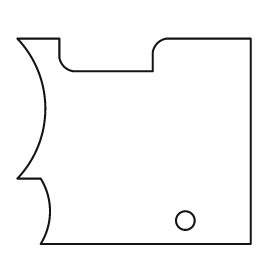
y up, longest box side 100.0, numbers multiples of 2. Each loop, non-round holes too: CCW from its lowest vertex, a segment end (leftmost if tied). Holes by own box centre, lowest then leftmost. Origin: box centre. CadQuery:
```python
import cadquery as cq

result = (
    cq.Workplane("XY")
    .moveTo(-40.0, -44.0)
    .lineTo(50.0, -44.0)
    .lineTo(50.0, 44.0)
    .lineTo(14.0, 44.0)
    .threePointArc((10.0, 42.0), (8.0, 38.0))
    .lineTo(8.0, 30.0)
    .lineTo(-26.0, 30.0)
    .threePointArc((-30.0, 32.0), (-32.0, 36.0))
    .lineTo(-32.0, 44.0)
    .lineTo(-50.0, 44.0)
    .threePointArc((-38.0, 14.0), (-50.0, -16.0))
    .lineTo(-40.0, -16.0)
    .threePointArc((-36.0, -30.0), (-40.0, -44.0))
    .close()
    .moveTo(22.0, -34.0)
    .circle(4.0)
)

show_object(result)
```